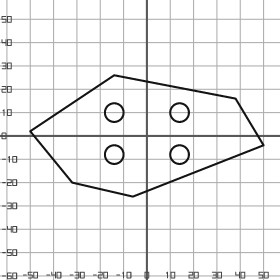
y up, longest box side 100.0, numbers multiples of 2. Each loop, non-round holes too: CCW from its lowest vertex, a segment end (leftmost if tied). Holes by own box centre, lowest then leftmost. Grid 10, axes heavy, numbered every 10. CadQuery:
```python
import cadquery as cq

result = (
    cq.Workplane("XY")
    .moveTo(-6.0, -26.0)
    .lineTo(50.0, -4.0)
    .lineTo(38.0, 16.0)
    .lineTo(-14.0, 26.0)
    .lineTo(-50.0, 2.0)
    .lineTo(-32.0, -20.0)
    .close()
    .moveTo(-14.0, -8.0)
    .circle(4.0)
    .moveTo(14.0, -8.0)
    .circle(4.0)
    .moveTo(-14.0, 10.0)
    .circle(4.0)
    .moveTo(14.0, 10.0)
    .circle(4.0)
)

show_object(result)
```